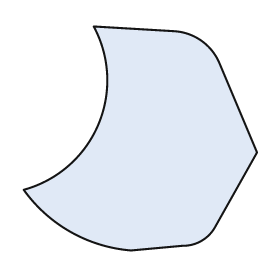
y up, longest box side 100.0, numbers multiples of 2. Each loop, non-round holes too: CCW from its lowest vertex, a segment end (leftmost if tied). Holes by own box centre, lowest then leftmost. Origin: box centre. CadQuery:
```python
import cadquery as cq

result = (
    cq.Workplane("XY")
    .moveTo(-4.0, -48.0)
    .lineTo(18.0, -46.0)
    .threePointArc((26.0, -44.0), (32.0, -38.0))
    .lineTo(50.0, -6.0)
    .lineTo(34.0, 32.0)
    .threePointArc((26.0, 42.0), (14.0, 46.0))
    .lineTo(-20.0, 48.0)
    .threePointArc((-18.0, 6.0), (-50.0, -22.0))
    .threePointArc((-30.0, -40.0), (-4.0, -48.0))
    .close()
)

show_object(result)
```